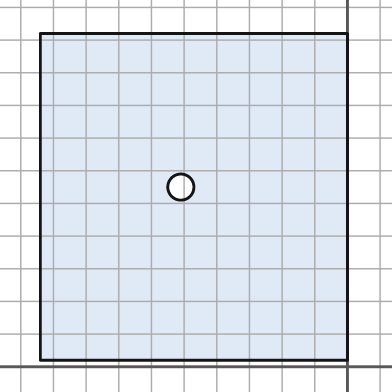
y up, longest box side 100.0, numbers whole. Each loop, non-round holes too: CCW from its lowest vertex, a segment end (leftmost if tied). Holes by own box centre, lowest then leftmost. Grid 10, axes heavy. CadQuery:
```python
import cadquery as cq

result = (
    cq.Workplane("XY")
    .moveTo(-94.0, 2.0)
    .lineTo(0.0, 2.0)
    .lineTo(0.0, 102.0)
    .lineTo(-94.0, 102.0)
    .close()
    .moveTo(-51.0, 55.0)
    .circle(4.0)
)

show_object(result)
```